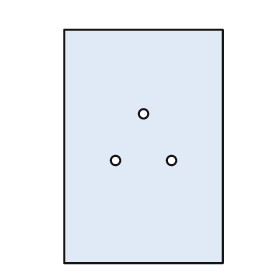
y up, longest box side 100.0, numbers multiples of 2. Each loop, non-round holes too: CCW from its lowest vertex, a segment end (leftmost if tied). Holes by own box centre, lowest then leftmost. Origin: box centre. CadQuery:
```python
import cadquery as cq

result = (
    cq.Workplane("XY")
    .moveTo(-34.0, -50.0)
    .lineTo(34.0, -50.0)
    .lineTo(34.0, 50.0)
    .lineTo(-34.0, 50.0)
    .close()
    .moveTo(-12.0, -6.0)
    .circle(2.0)
    .moveTo(12.0, -6.0)
    .circle(2.0)
    .moveTo(0.0, 14.0)
    .circle(2.0)
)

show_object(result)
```